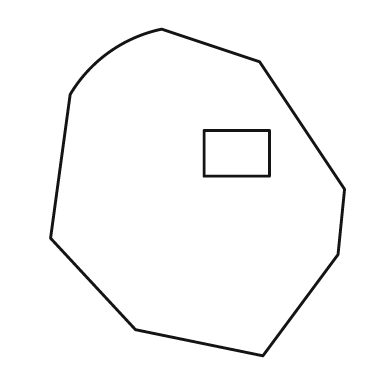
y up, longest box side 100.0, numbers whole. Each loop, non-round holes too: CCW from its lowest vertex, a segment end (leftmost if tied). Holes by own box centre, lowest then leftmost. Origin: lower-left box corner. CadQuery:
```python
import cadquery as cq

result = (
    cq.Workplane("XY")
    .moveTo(65.0, 0.0)
    .lineTo(88.0, 31.0)
    .lineTo(90.0, 51.0)
    .lineTo(64.0, 90.0)
    .lineTo(34.0, 100.0)
    .threePointArc((18.0, 93.0), (6.0, 80.0))
    .lineTo(0.0, 36.0)
    .lineTo(26.0, 8.0)
    .close()
    .moveTo(47.0, 55.0)
    .lineTo(67.0, 55.0)
    .lineTo(67.0, 69.0)
    .lineTo(47.0, 69.0)
    .close()
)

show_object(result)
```